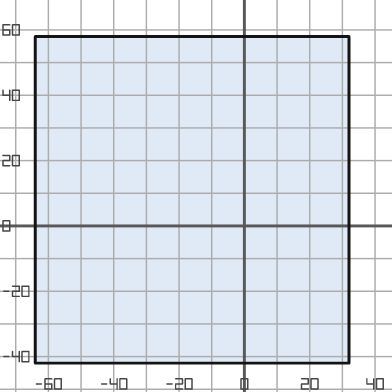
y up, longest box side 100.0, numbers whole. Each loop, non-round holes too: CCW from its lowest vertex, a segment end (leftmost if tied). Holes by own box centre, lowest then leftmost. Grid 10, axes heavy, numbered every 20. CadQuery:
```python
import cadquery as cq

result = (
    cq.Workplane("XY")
    .moveTo(-64.0, -42.0)
    .lineTo(32.0, -42.0)
    .lineTo(32.0, 58.0)
    .lineTo(-64.0, 58.0)
    .close()
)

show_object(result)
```